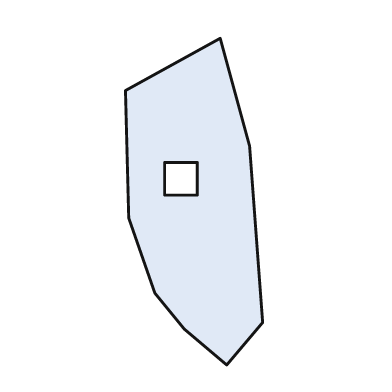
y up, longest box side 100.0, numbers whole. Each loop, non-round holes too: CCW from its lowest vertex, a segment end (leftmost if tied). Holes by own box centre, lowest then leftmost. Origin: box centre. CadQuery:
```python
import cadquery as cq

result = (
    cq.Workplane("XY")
    .moveTo(10.0, -50.0)
    .lineTo(21.0, -37.0)
    .lineTo(17.0, 17.0)
    .lineTo(8.0, 50.0)
    .lineTo(-21.0, 34.0)
    .lineTo(-20.0, -5.0)
    .lineTo(-12.0, -28.0)
    .lineTo(-3.0, -39.0)
    .close()
    .moveTo(-9.0, 2.0)
    .lineTo(1.0, 2.0)
    .lineTo(1.0, 12.0)
    .lineTo(-9.0, 12.0)
    .close()
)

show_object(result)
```